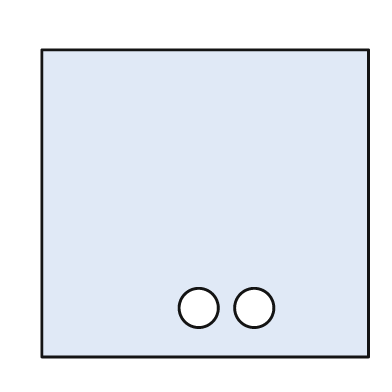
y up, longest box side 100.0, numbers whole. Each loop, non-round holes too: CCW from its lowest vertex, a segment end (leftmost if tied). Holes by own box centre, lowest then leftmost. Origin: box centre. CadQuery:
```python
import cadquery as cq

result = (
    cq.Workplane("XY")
    .moveTo(-50.0, -47.0)
    .lineTo(50.0, -47.0)
    .lineTo(50.0, 47.0)
    .lineTo(-50.0, 47.0)
    .close()
    .moveTo(-2.0, -32.0)
    .circle(6.0)
    .moveTo(15.0, -32.0)
    .circle(6.0)
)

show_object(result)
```